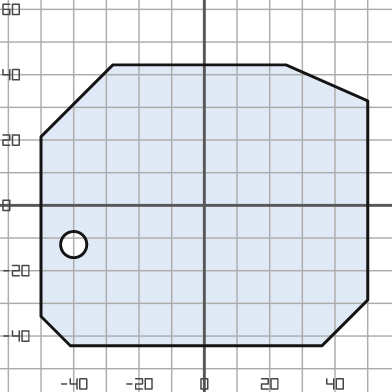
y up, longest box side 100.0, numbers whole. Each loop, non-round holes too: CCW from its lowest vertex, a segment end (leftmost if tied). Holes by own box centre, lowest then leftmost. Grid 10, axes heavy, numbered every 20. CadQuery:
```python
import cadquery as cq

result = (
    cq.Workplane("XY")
    .moveTo(-41.0, -43.0)
    .lineTo(36.0, -43.0)
    .lineTo(50.0, -29.0)
    .lineTo(50.0, 32.0)
    .lineTo(25.0, 43.0)
    .lineTo(-28.0, 43.0)
    .lineTo(-50.0, 21.0)
    .lineTo(-50.0, -34.0)
    .close()
    .moveTo(-40.0, -12.0)
    .circle(4.0)
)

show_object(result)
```